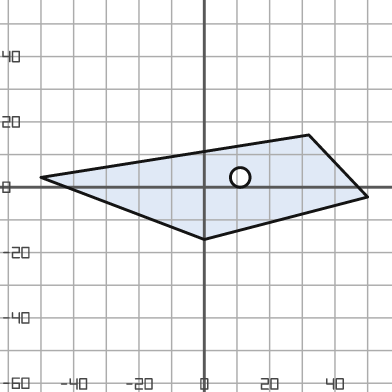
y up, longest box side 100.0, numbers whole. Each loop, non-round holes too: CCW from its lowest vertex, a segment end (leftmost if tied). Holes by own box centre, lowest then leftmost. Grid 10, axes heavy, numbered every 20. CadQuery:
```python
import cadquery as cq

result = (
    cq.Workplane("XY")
    .moveTo(0.0, -16.0)
    .lineTo(50.0, -3.0)
    .lineTo(32.0, 16.0)
    .lineTo(-50.0, 3.0)
    .close()
    .moveTo(11.0, 3.0)
    .circle(3.0)
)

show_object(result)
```